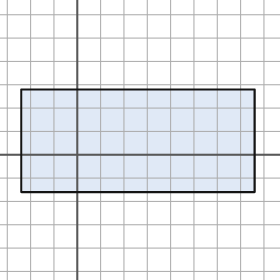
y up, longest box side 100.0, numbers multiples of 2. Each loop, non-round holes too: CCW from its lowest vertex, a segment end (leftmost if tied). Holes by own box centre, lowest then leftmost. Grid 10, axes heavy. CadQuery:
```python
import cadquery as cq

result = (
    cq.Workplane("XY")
    .moveTo(-24.0, -16.0)
    .lineTo(76.0, -16.0)
    .lineTo(76.0, 28.0)
    .lineTo(-24.0, 28.0)
    .close()
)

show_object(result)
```